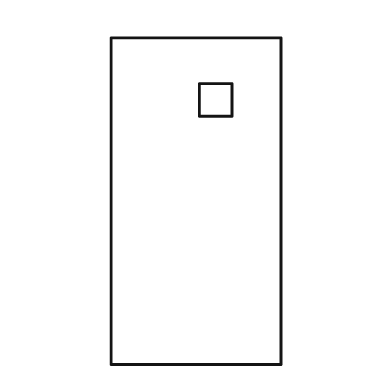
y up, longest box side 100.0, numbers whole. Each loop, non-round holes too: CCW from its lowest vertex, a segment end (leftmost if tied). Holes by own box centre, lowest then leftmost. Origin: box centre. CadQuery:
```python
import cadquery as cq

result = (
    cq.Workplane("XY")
    .moveTo(-26.0, -50.0)
    .lineTo(26.0, -50.0)
    .lineTo(26.0, 50.0)
    .lineTo(-26.0, 50.0)
    .close()
    .moveTo(1.0, 26.0)
    .lineTo(11.0, 26.0)
    .lineTo(11.0, 36.0)
    .lineTo(1.0, 36.0)
    .close()
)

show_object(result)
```